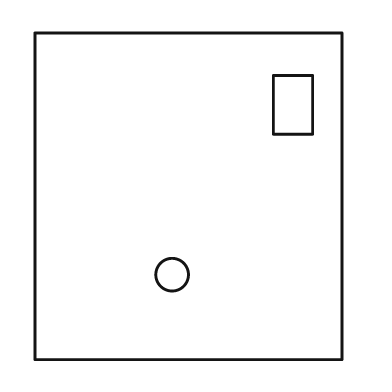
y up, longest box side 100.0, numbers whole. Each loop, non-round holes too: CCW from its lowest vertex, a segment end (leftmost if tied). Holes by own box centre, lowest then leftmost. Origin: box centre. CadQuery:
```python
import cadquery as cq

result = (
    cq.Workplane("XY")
    .moveTo(-47.0, -50.0)
    .lineTo(47.0, -50.0)
    .lineTo(47.0, 50.0)
    .lineTo(-47.0, 50.0)
    .close()
    .moveTo(-5.0, -24.0)
    .circle(5.0)
    .moveTo(26.0, 19.0)
    .lineTo(38.0, 19.0)
    .lineTo(38.0, 37.0)
    .lineTo(26.0, 37.0)
    .close()
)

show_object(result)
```